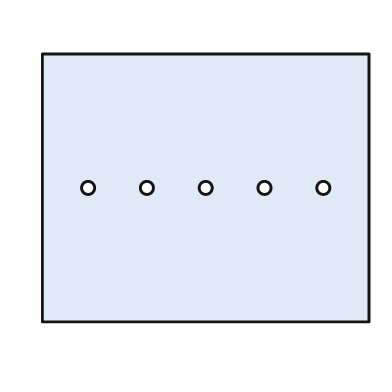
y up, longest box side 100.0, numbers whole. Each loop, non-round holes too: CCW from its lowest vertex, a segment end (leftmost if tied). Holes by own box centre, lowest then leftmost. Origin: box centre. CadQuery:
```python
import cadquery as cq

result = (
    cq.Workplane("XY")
    .moveTo(-50.0, -41.0)
    .lineTo(50.0, -41.0)
    .lineTo(50.0, 41.0)
    .lineTo(-50.0, 41.0)
    .close()
    .moveTo(-36.0, 0.0)
    .circle(2.0)
    .moveTo(-18.0, 0.0)
    .circle(2.0)
    .moveTo(0.0, 0.0)
    .circle(2.0)
    .moveTo(18.0, 0.0)
    .circle(2.0)
    .moveTo(36.0, 0.0)
    .circle(2.0)
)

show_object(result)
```